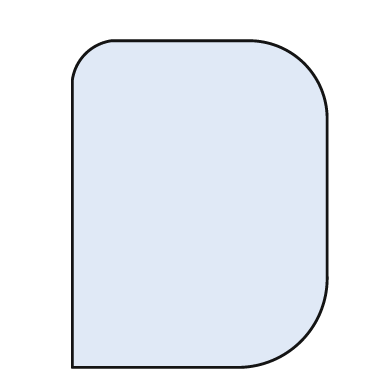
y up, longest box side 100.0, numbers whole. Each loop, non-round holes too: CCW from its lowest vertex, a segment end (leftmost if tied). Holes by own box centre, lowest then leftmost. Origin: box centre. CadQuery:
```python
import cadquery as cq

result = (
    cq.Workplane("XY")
    .moveTo(-39.0, -50.0)
    .lineTo(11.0, -50.0)
    .threePointArc((31.0, -42.0), (39.0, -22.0))
    .lineTo(39.0, 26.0)
    .threePointArc((32.0, 43.0), (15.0, 50.0))
    .lineTo(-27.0, 50.0)
    .threePointArc((-35.0, 46.0), (-39.0, 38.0))
    .close()
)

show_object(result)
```